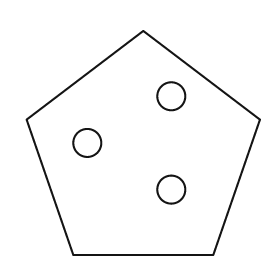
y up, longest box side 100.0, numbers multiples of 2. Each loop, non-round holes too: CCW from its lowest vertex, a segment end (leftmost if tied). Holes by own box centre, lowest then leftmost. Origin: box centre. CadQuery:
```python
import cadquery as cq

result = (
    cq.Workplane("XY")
    .moveTo(-30.0, -48.0)
    .lineTo(30.0, -48.0)
    .lineTo(50.0, 10.0)
    .lineTo(0.0, 48.0)
    .lineTo(-50.0, 10.0)
    .close()
    .moveTo(12.0, -20.0)
    .circle(6.0)
    .moveTo(-24.0, 0.0)
    .circle(6.0)
    .moveTo(12.0, 20.0)
    .circle(6.0)
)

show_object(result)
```